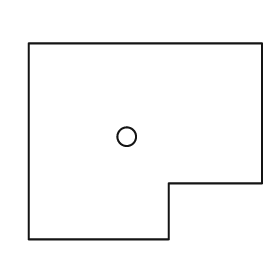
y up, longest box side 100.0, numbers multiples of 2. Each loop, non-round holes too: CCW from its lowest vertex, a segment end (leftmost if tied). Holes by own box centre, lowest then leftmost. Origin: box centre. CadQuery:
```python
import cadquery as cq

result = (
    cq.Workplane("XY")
    .moveTo(-50.0, -42.0)
    .lineTo(10.0, -42.0)
    .lineTo(10.0, -18.0)
    .lineTo(50.0, -18.0)
    .lineTo(50.0, 42.0)
    .lineTo(-50.0, 42.0)
    .close()
    .moveTo(-8.0, 2.0)
    .circle(4.0)
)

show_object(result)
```